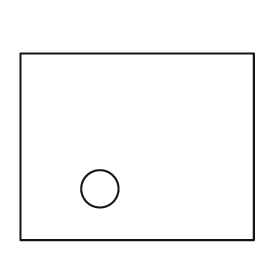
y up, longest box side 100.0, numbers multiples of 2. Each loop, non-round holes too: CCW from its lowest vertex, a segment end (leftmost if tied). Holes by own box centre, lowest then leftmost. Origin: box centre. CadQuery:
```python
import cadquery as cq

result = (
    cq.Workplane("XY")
    .moveTo(-50.0, -40.0)
    .lineTo(50.0, -40.0)
    .lineTo(50.0, 40.0)
    .lineTo(-50.0, 40.0)
    .close()
    .moveTo(-16.0, -18.0)
    .circle(8.0)
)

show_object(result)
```